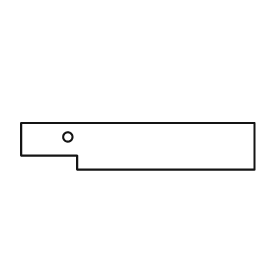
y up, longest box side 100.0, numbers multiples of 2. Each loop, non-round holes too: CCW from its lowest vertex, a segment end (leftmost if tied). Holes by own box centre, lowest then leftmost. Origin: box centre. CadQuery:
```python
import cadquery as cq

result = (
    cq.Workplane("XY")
    .moveTo(-26.0, -10.0)
    .lineTo(50.0, -10.0)
    .lineTo(50.0, 10.0)
    .lineTo(-50.0, 10.0)
    .lineTo(-50.0, -4.0)
    .lineTo(-26.0, -4.0)
    .close()
    .moveTo(-30.0, 4.0)
    .circle(2.0)
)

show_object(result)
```